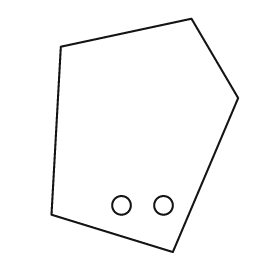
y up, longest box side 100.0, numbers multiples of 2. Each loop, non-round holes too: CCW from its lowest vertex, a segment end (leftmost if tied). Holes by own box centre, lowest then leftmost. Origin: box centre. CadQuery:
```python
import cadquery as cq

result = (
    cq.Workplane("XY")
    .moveTo(12.0, -50.0)
    .lineTo(40.0, 16.0)
    .lineTo(20.0, 50.0)
    .lineTo(-36.0, 38.0)
    .lineTo(-40.0, -34.0)
    .close()
    .moveTo(-10.0, -30.0)
    .circle(4.0)
    .moveTo(8.0, -30.0)
    .circle(4.0)
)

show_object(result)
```